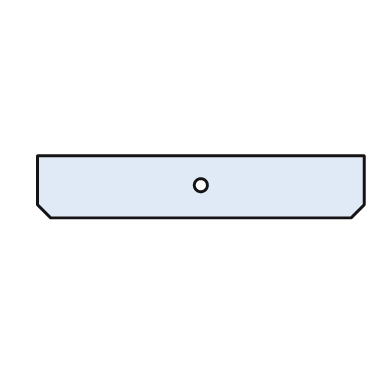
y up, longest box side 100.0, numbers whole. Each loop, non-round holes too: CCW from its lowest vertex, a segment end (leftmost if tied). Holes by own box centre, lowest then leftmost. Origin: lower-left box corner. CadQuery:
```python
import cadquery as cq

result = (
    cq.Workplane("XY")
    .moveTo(4.0, 0.0)
    .lineTo(96.0, 0.0)
    .lineTo(100.0, 4.0)
    .lineTo(100.0, 19.0)
    .lineTo(0.0, 19.0)
    .lineTo(0.0, 4.0)
    .close()
    .moveTo(50.0, 10.0)
    .circle(2.0)
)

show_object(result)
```